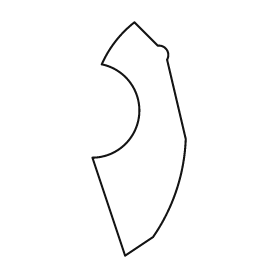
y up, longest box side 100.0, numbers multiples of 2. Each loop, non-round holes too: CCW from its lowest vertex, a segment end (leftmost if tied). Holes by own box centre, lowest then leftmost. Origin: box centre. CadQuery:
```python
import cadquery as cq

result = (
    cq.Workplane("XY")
    .moveTo(-6.0, -50.0)
    .lineTo(6.0, -42.0)
    .threePointArc((16.0, -22.0), (20.0, 0.0))
    .lineTo(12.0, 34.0)
    .threePointArc((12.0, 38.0), (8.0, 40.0))
    .lineTo(-2.0, 50.0)
    .threePointArc((-10.0, 42.0), (-16.0, 32.0))
    .threePointArc((0.0, 10.0), (-20.0, -8.0))
    .close()
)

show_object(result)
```